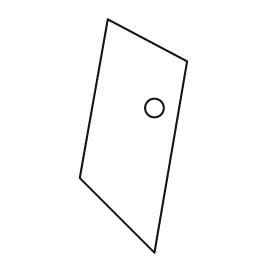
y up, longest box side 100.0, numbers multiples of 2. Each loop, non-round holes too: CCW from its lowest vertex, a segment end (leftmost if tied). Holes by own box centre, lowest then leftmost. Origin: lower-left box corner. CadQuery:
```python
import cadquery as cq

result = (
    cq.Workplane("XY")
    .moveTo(32.0, 0.0)
    .lineTo(46.0, 82.0)
    .lineTo(12.0, 100.0)
    .lineTo(0.0, 32.0)
    .close()
    .moveTo(32.0, 62.0)
    .circle(4.0)
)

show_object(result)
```